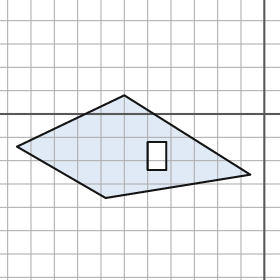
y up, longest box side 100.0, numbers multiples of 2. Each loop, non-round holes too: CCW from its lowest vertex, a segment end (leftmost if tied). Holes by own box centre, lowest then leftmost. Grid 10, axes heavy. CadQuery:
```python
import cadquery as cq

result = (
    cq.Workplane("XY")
    .moveTo(-68.0, -36.0)
    .lineTo(-6.0, -26.0)
    .lineTo(-60.0, 8.0)
    .lineTo(-106.0, -14.0)
    .close()
    .moveTo(-50.0, -24.0)
    .lineTo(-42.0, -24.0)
    .lineTo(-42.0, -12.0)
    .lineTo(-50.0, -12.0)
    .close()
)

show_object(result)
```